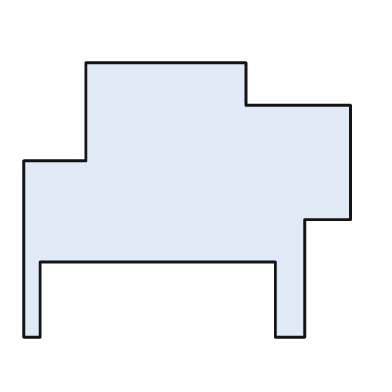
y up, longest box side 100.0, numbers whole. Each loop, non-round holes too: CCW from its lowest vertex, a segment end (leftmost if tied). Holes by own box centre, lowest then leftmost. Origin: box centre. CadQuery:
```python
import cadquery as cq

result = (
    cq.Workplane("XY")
    .moveTo(-50.0, -42.0)
    .lineTo(-45.0, -42.0)
    .lineTo(-45.0, -19.0)
    .lineTo(27.0, -19.0)
    .lineTo(27.0, -42.0)
    .lineTo(36.0, -42.0)
    .lineTo(36.0, -6.0)
    .lineTo(50.0, -6.0)
    .lineTo(50.0, 29.0)
    .lineTo(18.0, 29.0)
    .lineTo(18.0, 42.0)
    .lineTo(-31.0, 42.0)
    .lineTo(-31.0, 12.0)
    .lineTo(-50.0, 12.0)
    .close()
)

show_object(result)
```